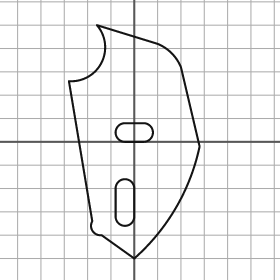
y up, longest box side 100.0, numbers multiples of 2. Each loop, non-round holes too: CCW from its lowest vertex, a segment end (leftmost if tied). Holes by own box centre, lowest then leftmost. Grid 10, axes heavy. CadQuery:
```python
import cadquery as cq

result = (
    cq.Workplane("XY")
    .moveTo(0.0, -50.0)
    .threePointArc((18.0, -28.0), (28.0, -2.0))
    .lineTo(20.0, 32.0)
    .threePointArc((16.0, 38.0), (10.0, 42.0))
    .lineTo(-16.0, 50.0)
    .threePointArc((-14.0, 34.0), (-28.0, 26.0))
    .lineTo(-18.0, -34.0)
    .threePointArc((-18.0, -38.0), (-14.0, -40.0))
    .close()
    .moveTo(-8.0, -32.0)
    .threePointArc((-4.0, -36.0), (0.0, -32.0))
    .lineTo(0.0, -20.0)
    .threePointArc((-4.0, -16.0), (-8.0, -20.0))
    .close()
    .moveTo(-4.0, 0.0)
    .lineTo(4.0, 0.0)
    .threePointArc((8.0, 4.0), (4.0, 8.0))
    .lineTo(-4.0, 8.0)
    .threePointArc((-8.0, 4.0), (-4.0, 0.0))
    .close()
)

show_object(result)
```